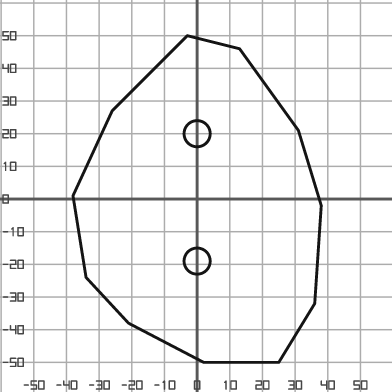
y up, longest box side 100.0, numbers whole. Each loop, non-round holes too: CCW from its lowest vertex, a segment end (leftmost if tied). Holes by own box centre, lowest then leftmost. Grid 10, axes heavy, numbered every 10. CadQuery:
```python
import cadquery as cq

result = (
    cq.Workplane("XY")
    .moveTo(2.0, -50.0)
    .lineTo(25.0, -50.0)
    .lineTo(36.0, -32.0)
    .lineTo(38.0, -2.0)
    .lineTo(31.0, 21.0)
    .lineTo(13.0, 46.0)
    .lineTo(-3.0, 50.0)
    .lineTo(-26.0, 27.0)
    .lineTo(-38.0, 1.0)
    .lineTo(-34.0, -24.0)
    .lineTo(-21.0, -38.0)
    .close()
    .moveTo(0.0, -19.0)
    .circle(4.0)
    .moveTo(0.0, 20.0)
    .circle(4.0)
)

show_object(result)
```